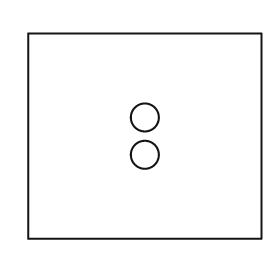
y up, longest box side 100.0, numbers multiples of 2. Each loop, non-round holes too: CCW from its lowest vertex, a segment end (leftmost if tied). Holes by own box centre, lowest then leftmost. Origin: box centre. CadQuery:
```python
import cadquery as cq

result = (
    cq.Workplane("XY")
    .moveTo(-50.0, -44.0)
    .lineTo(50.0, -44.0)
    .lineTo(50.0, 44.0)
    .lineTo(-50.0, 44.0)
    .close()
    .moveTo(0.0, -8.0)
    .circle(6.0)
    .moveTo(0.0, 8.0)
    .circle(6.0)
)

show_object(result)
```